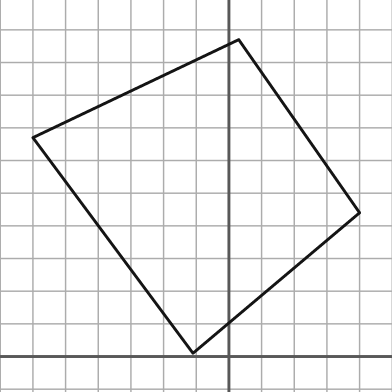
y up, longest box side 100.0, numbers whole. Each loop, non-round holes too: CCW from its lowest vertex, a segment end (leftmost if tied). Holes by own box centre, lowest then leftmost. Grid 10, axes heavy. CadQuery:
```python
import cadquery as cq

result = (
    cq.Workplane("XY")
    .moveTo(-11.0, 1.0)
    .lineTo(40.0, 44.0)
    .lineTo(3.0, 97.0)
    .lineTo(-60.0, 67.0)
    .close()
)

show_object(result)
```